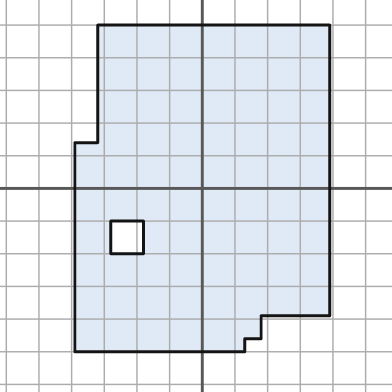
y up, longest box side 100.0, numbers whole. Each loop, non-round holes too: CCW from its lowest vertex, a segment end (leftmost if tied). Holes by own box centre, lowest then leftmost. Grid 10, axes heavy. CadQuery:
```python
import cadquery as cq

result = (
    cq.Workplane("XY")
    .moveTo(-39.0, -50.0)
    .lineTo(13.0, -50.0)
    .lineTo(13.0, -46.0)
    .lineTo(18.0, -46.0)
    .lineTo(18.0, -39.0)
    .lineTo(39.0, -39.0)
    .lineTo(39.0, 50.0)
    .lineTo(-32.0, 50.0)
    .lineTo(-32.0, 14.0)
    .lineTo(-39.0, 14.0)
    .close()
    .moveTo(-28.0, -20.0)
    .lineTo(-18.0, -20.0)
    .lineTo(-18.0, -10.0)
    .lineTo(-28.0, -10.0)
    .close()
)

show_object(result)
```